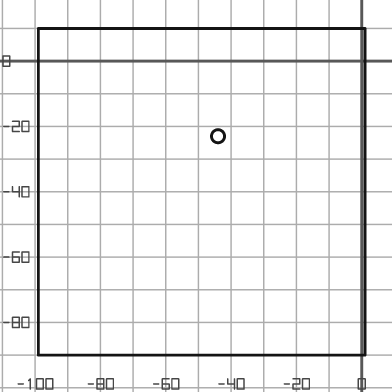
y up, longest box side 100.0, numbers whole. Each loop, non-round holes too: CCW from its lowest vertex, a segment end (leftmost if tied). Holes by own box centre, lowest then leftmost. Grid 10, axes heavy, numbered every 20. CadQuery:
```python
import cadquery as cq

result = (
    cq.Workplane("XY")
    .moveTo(-99.0, -90.0)
    .lineTo(1.0, -90.0)
    .lineTo(1.0, 10.0)
    .lineTo(-99.0, 10.0)
    .close()
    .moveTo(-44.0, -23.0)
    .circle(2.0)
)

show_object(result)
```